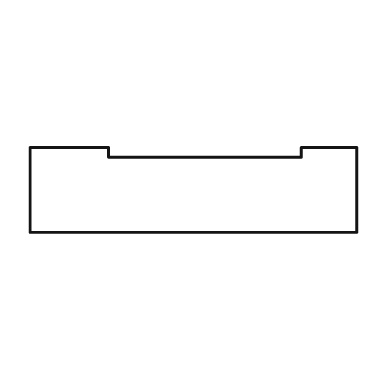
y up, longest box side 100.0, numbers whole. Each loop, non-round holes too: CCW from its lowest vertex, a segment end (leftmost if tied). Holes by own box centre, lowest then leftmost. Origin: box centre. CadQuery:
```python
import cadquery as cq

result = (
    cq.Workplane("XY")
    .moveTo(-50.0, -13.0)
    .lineTo(50.0, -13.0)
    .lineTo(50.0, 13.0)
    .lineTo(33.0, 13.0)
    .lineTo(33.0, 10.0)
    .lineTo(-26.0, 10.0)
    .lineTo(-26.0, 13.0)
    .lineTo(-50.0, 13.0)
    .close()
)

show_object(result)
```